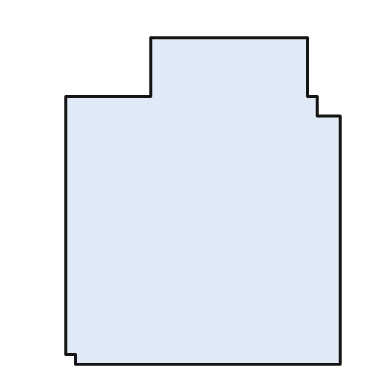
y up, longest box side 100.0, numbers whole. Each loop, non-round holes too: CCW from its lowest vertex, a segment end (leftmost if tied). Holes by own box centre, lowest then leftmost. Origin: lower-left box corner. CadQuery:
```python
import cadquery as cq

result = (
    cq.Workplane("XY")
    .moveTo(3.0, 0.0)
    .lineTo(84.0, 0.0)
    .lineTo(84.0, 76.0)
    .lineTo(77.0, 76.0)
    .lineTo(77.0, 82.0)
    .lineTo(74.0, 82.0)
    .lineTo(74.0, 100.0)
    .lineTo(26.0, 100.0)
    .lineTo(26.0, 82.0)
    .lineTo(0.0, 82.0)
    .lineTo(0.0, 3.0)
    .lineTo(3.0, 3.0)
    .close()
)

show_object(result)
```